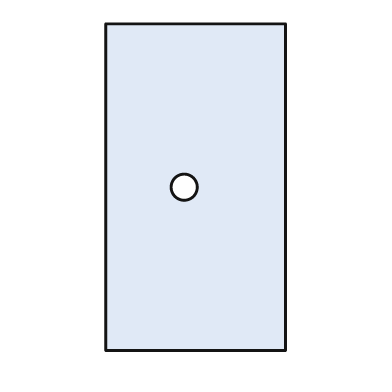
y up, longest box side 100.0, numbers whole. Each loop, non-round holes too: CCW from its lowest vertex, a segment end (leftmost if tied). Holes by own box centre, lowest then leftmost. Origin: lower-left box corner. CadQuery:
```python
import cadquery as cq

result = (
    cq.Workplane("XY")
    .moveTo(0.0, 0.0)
    .lineTo(55.0, 0.0)
    .lineTo(55.0, 100.0)
    .lineTo(0.0, 100.0)
    .close()
    .moveTo(24.0, 50.0)
    .circle(4.0)
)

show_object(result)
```